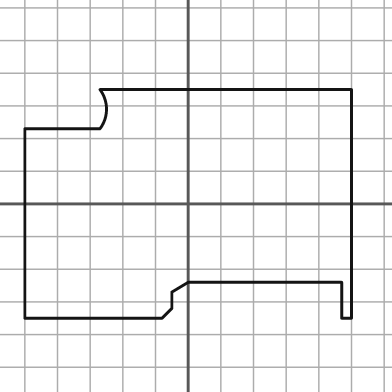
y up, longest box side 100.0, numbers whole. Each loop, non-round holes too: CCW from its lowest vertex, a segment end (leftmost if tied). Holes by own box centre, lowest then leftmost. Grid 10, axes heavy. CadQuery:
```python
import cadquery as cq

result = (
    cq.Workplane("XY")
    .moveTo(-50.0, -35.0)
    .lineTo(-8.0, -35.0)
    .lineTo(-5.0, -32.0)
    .lineTo(-5.0, -27.0)
    .lineTo(0.0, -24.0)
    .lineTo(47.0, -24.0)
    .lineTo(47.0, -35.0)
    .lineTo(50.0, -35.0)
    .lineTo(50.0, 35.0)
    .lineTo(-27.0, 35.0)
    .threePointArc((-25.0, 29.0), (-27.0, 23.0))
    .lineTo(-50.0, 23.0)
    .close()
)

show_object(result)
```